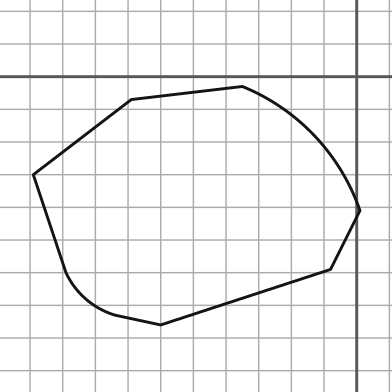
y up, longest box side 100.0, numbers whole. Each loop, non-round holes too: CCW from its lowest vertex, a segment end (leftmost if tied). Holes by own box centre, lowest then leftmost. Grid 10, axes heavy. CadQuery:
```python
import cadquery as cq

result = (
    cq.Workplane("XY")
    .moveTo(-60.0, -76.0)
    .lineTo(-8.0, -59.0)
    .lineTo(1.0, -41.0)
    .threePointArc((-13.0, -18.0), (-35.0, -3.0))
    .lineTo(-69.0, -7.0)
    .lineTo(-99.0, -30.0)
    .lineTo(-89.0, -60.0)
    .threePointArc((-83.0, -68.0), (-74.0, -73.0))
    .close()
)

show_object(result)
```